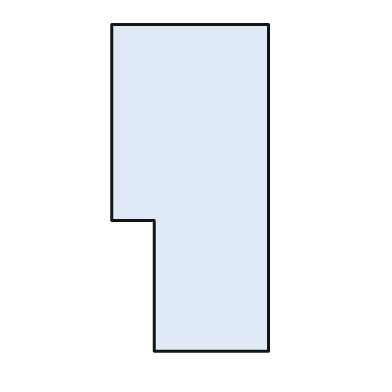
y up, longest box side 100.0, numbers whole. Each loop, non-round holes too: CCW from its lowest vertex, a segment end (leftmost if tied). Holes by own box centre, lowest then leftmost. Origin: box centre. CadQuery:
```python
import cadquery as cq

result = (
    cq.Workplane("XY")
    .moveTo(-11.0, -50.0)
    .lineTo(24.0, -50.0)
    .lineTo(24.0, 50.0)
    .lineTo(-24.0, 50.0)
    .lineTo(-24.0, -10.0)
    .lineTo(-11.0, -10.0)
    .close()
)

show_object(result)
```